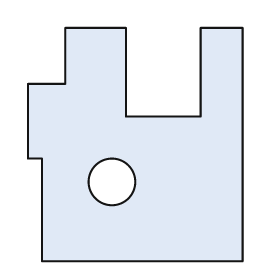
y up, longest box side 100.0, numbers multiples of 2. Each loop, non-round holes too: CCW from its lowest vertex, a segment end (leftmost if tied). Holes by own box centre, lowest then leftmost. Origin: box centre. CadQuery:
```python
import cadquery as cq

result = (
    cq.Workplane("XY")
    .moveTo(-40.0, -50.0)
    .lineTo(46.0, -50.0)
    .lineTo(46.0, 50.0)
    .lineTo(28.0, 50.0)
    .lineTo(28.0, 12.0)
    .lineTo(-4.0, 12.0)
    .lineTo(-4.0, 50.0)
    .lineTo(-30.0, 50.0)
    .lineTo(-30.0, 26.0)
    .lineTo(-46.0, 26.0)
    .lineTo(-46.0, -6.0)
    .lineTo(-40.0, -6.0)
    .close()
    .moveTo(-10.0, -16.0)
    .circle(10.0)
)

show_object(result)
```